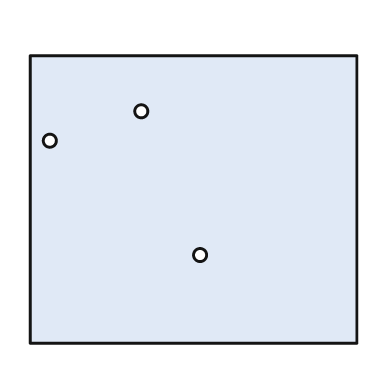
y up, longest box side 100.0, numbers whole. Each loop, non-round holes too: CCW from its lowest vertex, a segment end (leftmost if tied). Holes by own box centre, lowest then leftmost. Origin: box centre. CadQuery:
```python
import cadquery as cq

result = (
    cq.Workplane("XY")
    .moveTo(-50.0, -44.0)
    .lineTo(50.0, -44.0)
    .lineTo(50.0, 44.0)
    .lineTo(-50.0, 44.0)
    .close()
    .moveTo(2.0, -17.0)
    .circle(2.0)
    .moveTo(-44.0, 18.0)
    .circle(2.0)
    .moveTo(-16.0, 27.0)
    .circle(2.0)
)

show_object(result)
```